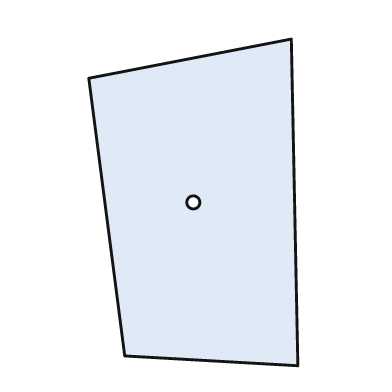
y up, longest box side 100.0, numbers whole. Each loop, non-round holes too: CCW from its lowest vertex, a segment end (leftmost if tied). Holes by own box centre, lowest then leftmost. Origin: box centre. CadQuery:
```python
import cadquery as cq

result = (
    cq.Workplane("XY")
    .moveTo(32.0, -50.0)
    .lineTo(30.0, 50.0)
    .lineTo(-32.0, 38.0)
    .lineTo(-21.0, -47.0)
    .close()
    .moveTo(0.0, 0.0)
    .circle(2.0)
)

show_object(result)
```